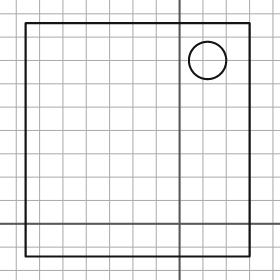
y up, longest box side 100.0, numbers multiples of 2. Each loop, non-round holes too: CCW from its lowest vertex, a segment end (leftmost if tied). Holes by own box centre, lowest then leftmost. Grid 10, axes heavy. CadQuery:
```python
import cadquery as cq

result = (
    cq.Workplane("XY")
    .moveTo(-66.0, -14.0)
    .lineTo(30.0, -14.0)
    .lineTo(30.0, 86.0)
    .lineTo(-66.0, 86.0)
    .close()
    .moveTo(12.0, 70.0)
    .circle(8.0)
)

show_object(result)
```